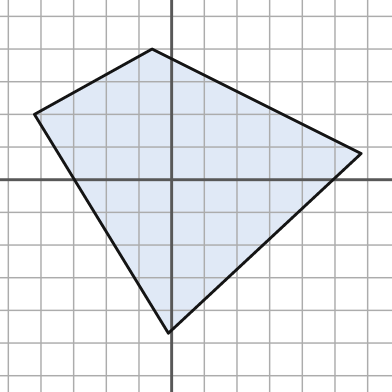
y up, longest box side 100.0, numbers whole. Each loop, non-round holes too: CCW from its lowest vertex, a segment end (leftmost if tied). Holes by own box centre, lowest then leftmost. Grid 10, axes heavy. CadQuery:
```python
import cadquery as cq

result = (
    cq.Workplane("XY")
    .moveTo(-1.0, -47.0)
    .lineTo(58.0, 8.0)
    .lineTo(-6.0, 40.0)
    .lineTo(-42.0, 20.0)
    .close()
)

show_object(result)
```